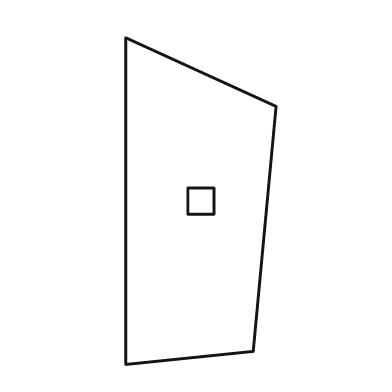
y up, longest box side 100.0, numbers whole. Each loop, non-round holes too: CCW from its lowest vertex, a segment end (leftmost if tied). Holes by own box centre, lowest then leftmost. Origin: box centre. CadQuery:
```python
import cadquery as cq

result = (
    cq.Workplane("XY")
    .moveTo(-23.0, -50.0)
    .lineTo(16.0, -46.0)
    .lineTo(23.0, 29.0)
    .lineTo(-23.0, 50.0)
    .close()
    .moveTo(-4.0, -4.0)
    .lineTo(4.0, -4.0)
    .lineTo(4.0, 4.0)
    .lineTo(-4.0, 4.0)
    .close()
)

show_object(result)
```